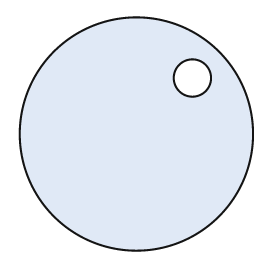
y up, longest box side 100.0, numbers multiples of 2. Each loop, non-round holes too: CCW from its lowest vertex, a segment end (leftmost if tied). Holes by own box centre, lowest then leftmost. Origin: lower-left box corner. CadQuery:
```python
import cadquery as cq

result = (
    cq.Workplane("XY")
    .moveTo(50.0, 50.0)
    .circle(50.0)
    .moveTo(74.0, 74.0)
    .circle(8.0)
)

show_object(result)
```